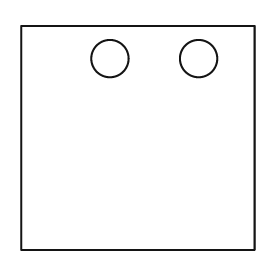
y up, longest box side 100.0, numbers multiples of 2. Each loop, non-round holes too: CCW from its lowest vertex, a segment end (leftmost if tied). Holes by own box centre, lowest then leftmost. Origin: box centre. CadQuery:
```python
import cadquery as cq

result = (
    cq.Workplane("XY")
    .moveTo(-50.0, -48.0)
    .lineTo(50.0, -48.0)
    .lineTo(50.0, 48.0)
    .lineTo(-50.0, 48.0)
    .close()
    .moveTo(-12.0, 34.0)
    .circle(8.0)
    .moveTo(26.0, 34.0)
    .circle(8.0)
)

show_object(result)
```